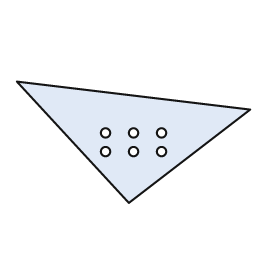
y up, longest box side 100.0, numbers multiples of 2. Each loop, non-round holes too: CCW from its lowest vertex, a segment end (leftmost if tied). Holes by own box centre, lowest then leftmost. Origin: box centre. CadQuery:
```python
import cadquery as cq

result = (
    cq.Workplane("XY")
    .moveTo(-2.0, -26.0)
    .lineTo(50.0, 14.0)
    .lineTo(-50.0, 26.0)
    .close()
    .moveTo(-12.0, -4.0)
    .circle(2.0)
    .moveTo(0.0, -4.0)
    .circle(2.0)
    .moveTo(12.0, -4.0)
    .circle(2.0)
    .moveTo(-12.0, 4.0)
    .circle(2.0)
    .moveTo(0.0, 4.0)
    .circle(2.0)
    .moveTo(12.0, 4.0)
    .circle(2.0)
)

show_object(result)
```